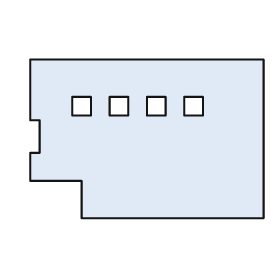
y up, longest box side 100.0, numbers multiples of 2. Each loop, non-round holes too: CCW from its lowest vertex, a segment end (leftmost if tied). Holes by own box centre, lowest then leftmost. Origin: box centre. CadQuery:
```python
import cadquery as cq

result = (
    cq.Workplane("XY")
    .moveTo(-28.0, -34.0)
    .lineTo(50.0, -34.0)
    .lineTo(50.0, 34.0)
    .lineTo(-50.0, 34.0)
    .lineTo(-50.0, 8.0)
    .lineTo(-46.0, 8.0)
    .lineTo(-46.0, -6.0)
    .lineTo(-50.0, -6.0)
    .lineTo(-50.0, -18.0)
    .lineTo(-28.0, -18.0)
    .close()
    .moveTo(-32.0, 10.0)
    .lineTo(-24.0, 10.0)
    .lineTo(-24.0, 18.0)
    .lineTo(-32.0, 18.0)
    .close()
    .moveTo(-16.0, 10.0)
    .lineTo(-8.0, 10.0)
    .lineTo(-8.0, 18.0)
    .lineTo(-16.0, 18.0)
    .close()
    .moveTo(0.0, 10.0)
    .lineTo(8.0, 10.0)
    .lineTo(8.0, 18.0)
    .lineTo(0.0, 18.0)
    .close()
    .moveTo(16.0, 10.0)
    .lineTo(24.0, 10.0)
    .lineTo(24.0, 18.0)
    .lineTo(16.0, 18.0)
    .close()
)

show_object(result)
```